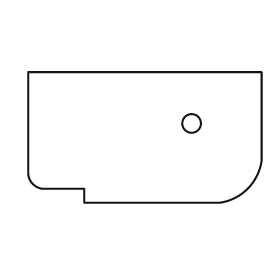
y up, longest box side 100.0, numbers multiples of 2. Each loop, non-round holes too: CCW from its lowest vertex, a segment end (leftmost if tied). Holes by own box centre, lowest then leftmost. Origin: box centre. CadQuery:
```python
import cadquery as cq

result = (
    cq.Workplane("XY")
    .moveTo(-26.0, -28.0)
    .lineTo(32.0, -28.0)
    .threePointArc((44.0, -22.0), (50.0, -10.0))
    .lineTo(50.0, 28.0)
    .lineTo(-50.0, 28.0)
    .lineTo(-50.0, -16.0)
    .threePointArc((-48.0, -20.0), (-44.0, -22.0))
    .lineTo(-26.0, -22.0)
    .close()
    .moveTo(20.0, 6.0)
    .circle(4.0)
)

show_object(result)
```